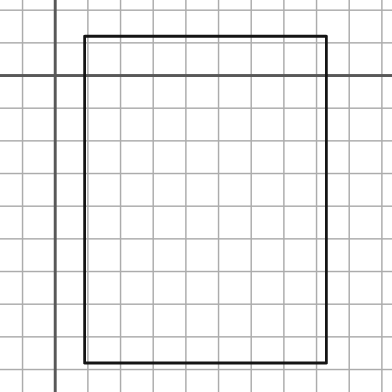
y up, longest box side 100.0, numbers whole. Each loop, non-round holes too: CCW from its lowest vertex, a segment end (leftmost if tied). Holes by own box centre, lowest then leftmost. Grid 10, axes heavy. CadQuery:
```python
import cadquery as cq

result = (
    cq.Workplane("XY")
    .moveTo(9.0, -88.0)
    .lineTo(83.0, -88.0)
    .lineTo(83.0, 12.0)
    .lineTo(9.0, 12.0)
    .close()
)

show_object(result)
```